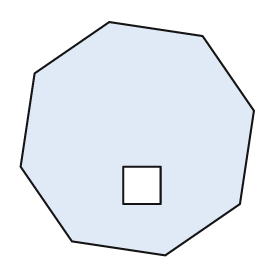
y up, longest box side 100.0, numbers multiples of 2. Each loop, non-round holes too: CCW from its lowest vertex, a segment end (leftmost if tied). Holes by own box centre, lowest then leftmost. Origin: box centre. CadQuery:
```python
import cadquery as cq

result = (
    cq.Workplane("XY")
    .moveTo(12.0, -50.0)
    .lineTo(44.0, -28.0)
    .lineTo(50.0, 12.0)
    .lineTo(28.0, 44.0)
    .lineTo(-12.0, 50.0)
    .lineTo(-44.0, 28.0)
    .lineTo(-50.0, -12.0)
    .lineTo(-28.0, -44.0)
    .close()
    .moveTo(-6.0, -28.0)
    .lineTo(10.0, -28.0)
    .lineTo(10.0, -12.0)
    .lineTo(-6.0, -12.0)
    .close()
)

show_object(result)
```